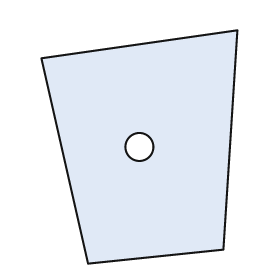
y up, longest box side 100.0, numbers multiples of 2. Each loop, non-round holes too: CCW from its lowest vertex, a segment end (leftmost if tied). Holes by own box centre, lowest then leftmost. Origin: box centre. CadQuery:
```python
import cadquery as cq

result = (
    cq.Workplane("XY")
    .moveTo(-22.0, -50.0)
    .lineTo(36.0, -44.0)
    .lineTo(42.0, 50.0)
    .lineTo(-42.0, 38.0)
    .close()
    .moveTo(0.0, 0.0)
    .circle(6.0)
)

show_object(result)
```